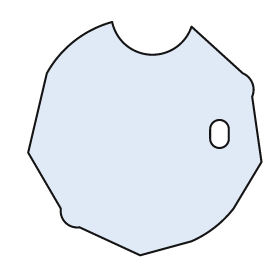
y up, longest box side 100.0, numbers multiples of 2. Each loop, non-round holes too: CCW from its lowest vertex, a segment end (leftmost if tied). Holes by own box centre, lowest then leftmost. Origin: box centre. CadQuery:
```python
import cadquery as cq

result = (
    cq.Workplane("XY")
    .moveTo(-2.0, -50.0)
    .lineTo(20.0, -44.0)
    .threePointArc((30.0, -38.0), (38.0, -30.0))
    .lineTo(50.0, -10.0)
    .lineTo(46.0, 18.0)
    .threePointArc((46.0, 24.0), (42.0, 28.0))
    .lineTo(20.0, 48.0)
    .threePointArc((2.0, 36.0), (-14.0, 50.0))
    .threePointArc((-30.0, 42.0), (-42.0, 28.0))
    .lineTo(-50.0, -6.0)
    .lineTo(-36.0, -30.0)
    .threePointArc((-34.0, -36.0), (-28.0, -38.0))
    .close()
    .moveTo(28.0, 0.0)
    .threePointArc((32.0, -4.0), (36.0, 0.0))
    .lineTo(36.0, 4.0)
    .threePointArc((32.0, 8.0), (28.0, 4.0))
    .close()
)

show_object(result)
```